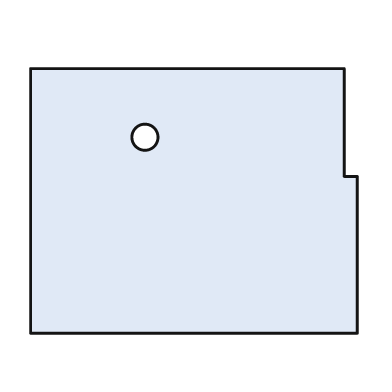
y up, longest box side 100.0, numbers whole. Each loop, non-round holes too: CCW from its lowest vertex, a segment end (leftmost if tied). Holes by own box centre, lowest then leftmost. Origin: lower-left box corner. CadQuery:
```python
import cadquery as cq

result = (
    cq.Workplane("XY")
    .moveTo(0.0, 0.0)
    .lineTo(100.0, 0.0)
    .lineTo(100.0, 48.0)
    .lineTo(96.0, 48.0)
    .lineTo(96.0, 81.0)
    .lineTo(0.0, 81.0)
    .close()
    .moveTo(35.0, 60.0)
    .circle(4.0)
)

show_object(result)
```